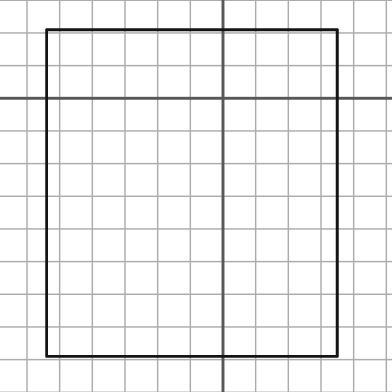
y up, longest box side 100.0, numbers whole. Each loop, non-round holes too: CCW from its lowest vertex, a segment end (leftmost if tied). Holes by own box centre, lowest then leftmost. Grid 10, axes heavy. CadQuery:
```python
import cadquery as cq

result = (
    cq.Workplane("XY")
    .moveTo(-54.0, -79.0)
    .lineTo(35.0, -79.0)
    .lineTo(35.0, 21.0)
    .lineTo(-54.0, 21.0)
    .close()
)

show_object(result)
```